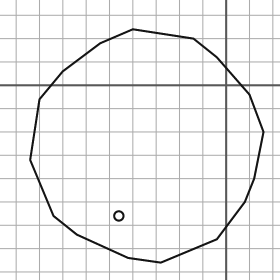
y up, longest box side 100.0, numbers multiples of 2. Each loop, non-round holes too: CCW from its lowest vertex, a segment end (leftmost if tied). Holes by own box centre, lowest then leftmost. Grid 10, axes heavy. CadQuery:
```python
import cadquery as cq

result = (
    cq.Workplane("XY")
    .moveTo(-28.0, -76.0)
    .lineTo(-4.0, -66.0)
    .lineTo(8.0, -50.0)
    .lineTo(12.0, -40.0)
    .lineTo(16.0, -20.0)
    .lineTo(10.0, -4.0)
    .lineTo(-4.0, 12.0)
    .lineTo(-14.0, 20.0)
    .lineTo(-40.0, 24.0)
    .lineTo(-54.0, 18.0)
    .lineTo(-70.0, 6.0)
    .lineTo(-80.0, -6.0)
    .lineTo(-84.0, -32.0)
    .lineTo(-74.0, -56.0)
    .lineTo(-64.0, -64.0)
    .lineTo(-42.0, -74.0)
    .close()
    .moveTo(-46.0, -56.0)
    .circle(2.0)
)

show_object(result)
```